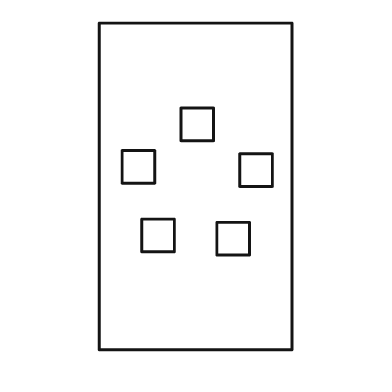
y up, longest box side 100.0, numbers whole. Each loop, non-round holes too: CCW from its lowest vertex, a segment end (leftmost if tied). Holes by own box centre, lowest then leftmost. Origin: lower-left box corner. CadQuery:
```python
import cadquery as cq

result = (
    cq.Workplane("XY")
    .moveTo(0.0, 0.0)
    .lineTo(59.0, 0.0)
    .lineTo(59.0, 100.0)
    .lineTo(0.0, 100.0)
    .close()
    .moveTo(36.0, 29.0)
    .lineTo(46.0, 29.0)
    .lineTo(46.0, 39.0)
    .lineTo(36.0, 39.0)
    .close()
    .moveTo(13.0, 30.0)
    .lineTo(23.0, 30.0)
    .lineTo(23.0, 40.0)
    .lineTo(13.0, 40.0)
    .close()
    .moveTo(43.0, 50.0)
    .lineTo(53.0, 50.0)
    .lineTo(53.0, 60.0)
    .lineTo(43.0, 60.0)
    .close()
    .moveTo(7.0, 51.0)
    .lineTo(17.0, 51.0)
    .lineTo(17.0, 61.0)
    .lineTo(7.0, 61.0)
    .close()
    .moveTo(25.0, 64.0)
    .lineTo(35.0, 64.0)
    .lineTo(35.0, 74.0)
    .lineTo(25.0, 74.0)
    .close()
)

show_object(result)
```